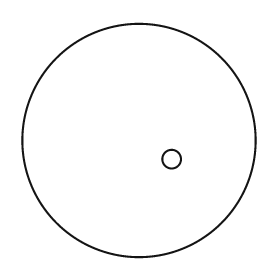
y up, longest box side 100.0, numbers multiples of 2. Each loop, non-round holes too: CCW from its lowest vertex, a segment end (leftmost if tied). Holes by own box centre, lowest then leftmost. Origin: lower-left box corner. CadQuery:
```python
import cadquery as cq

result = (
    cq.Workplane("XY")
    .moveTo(50.0, 50.0)
    .circle(50.0)
    .moveTo(64.0, 42.0)
    .circle(4.0)
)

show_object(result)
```